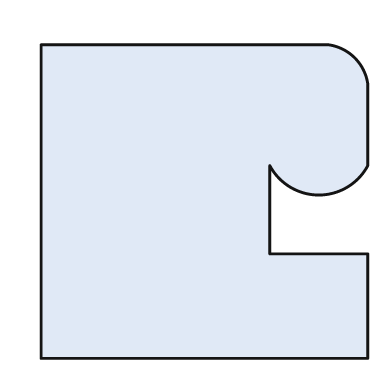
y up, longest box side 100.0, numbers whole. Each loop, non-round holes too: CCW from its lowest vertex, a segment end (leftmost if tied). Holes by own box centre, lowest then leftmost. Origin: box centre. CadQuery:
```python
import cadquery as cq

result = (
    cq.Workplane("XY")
    .moveTo(-50.0, -48.0)
    .lineTo(50.0, -48.0)
    .lineTo(50.0, -16.0)
    .lineTo(20.0, -16.0)
    .lineTo(20.0, 11.0)
    .threePointArc((35.0, 2.0), (50.0, 11.0))
    .lineTo(50.0, 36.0)
    .threePointArc((46.0, 44.0), (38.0, 48.0))
    .lineTo(-50.0, 48.0)
    .close()
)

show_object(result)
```